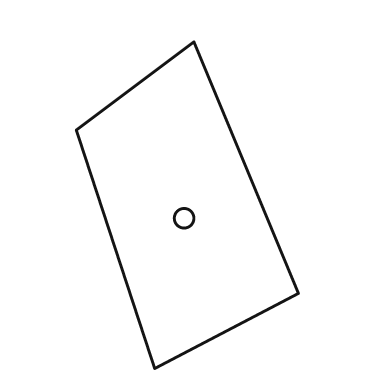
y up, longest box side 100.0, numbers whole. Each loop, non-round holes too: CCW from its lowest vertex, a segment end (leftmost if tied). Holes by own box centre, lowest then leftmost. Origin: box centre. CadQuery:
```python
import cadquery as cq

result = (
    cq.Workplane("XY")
    .moveTo(-10.0, -50.0)
    .lineTo(34.0, -27.0)
    .lineTo(2.0, 50.0)
    .lineTo(-34.0, 23.0)
    .close()
    .moveTo(-1.0, -4.0)
    .circle(3.0)
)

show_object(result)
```